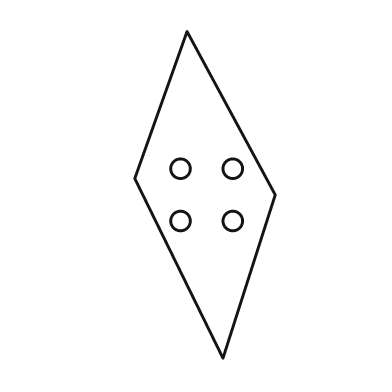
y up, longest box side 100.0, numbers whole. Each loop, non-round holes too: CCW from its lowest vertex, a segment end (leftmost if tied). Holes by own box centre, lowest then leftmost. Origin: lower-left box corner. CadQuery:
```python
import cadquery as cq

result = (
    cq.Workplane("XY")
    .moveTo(27.0, 0.0)
    .lineTo(43.0, 50.0)
    .lineTo(16.0, 100.0)
    .lineTo(0.0, 55.0)
    .close()
    .moveTo(14.0, 42.0)
    .circle(3.0)
    .moveTo(30.0, 42.0)
    .circle(3.0)
    .moveTo(14.0, 58.0)
    .circle(3.0)
    .moveTo(30.0, 58.0)
    .circle(3.0)
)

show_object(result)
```